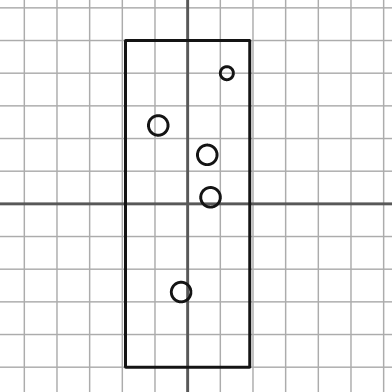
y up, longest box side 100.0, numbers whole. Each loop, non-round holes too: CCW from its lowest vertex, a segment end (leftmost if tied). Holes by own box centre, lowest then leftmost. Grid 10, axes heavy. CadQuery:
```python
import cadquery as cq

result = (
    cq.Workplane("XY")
    .moveTo(-19.0, -50.0)
    .lineTo(19.0, -50.0)
    .lineTo(19.0, 50.0)
    .lineTo(-19.0, 50.0)
    .close()
    .moveTo(-2.0, -27.0)
    .circle(3.0)
    .moveTo(7.0, 2.0)
    .circle(3.0)
    .moveTo(6.0, 15.0)
    .circle(3.0)
    .moveTo(-9.0, 24.0)
    .circle(3.0)
    .moveTo(12.0, 40.0)
    .circle(2.0)
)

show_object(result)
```